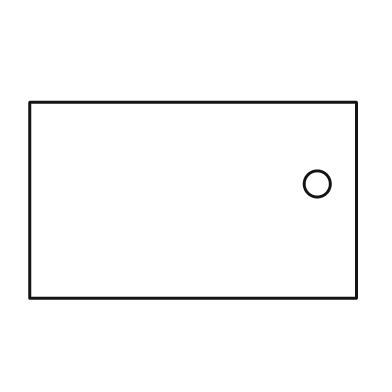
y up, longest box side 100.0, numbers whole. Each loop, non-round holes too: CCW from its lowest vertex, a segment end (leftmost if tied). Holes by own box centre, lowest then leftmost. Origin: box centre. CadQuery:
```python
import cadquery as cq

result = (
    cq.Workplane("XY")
    .moveTo(-50.0, -30.0)
    .lineTo(50.0, -30.0)
    .lineTo(50.0, 30.0)
    .lineTo(-50.0, 30.0)
    .close()
    .moveTo(38.0, 5.0)
    .circle(4.0)
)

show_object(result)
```